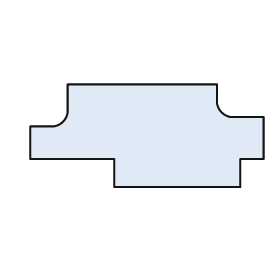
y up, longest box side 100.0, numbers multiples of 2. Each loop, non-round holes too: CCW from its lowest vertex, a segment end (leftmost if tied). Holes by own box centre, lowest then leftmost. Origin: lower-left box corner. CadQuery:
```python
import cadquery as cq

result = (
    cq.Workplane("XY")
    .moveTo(36.0, 0.0)
    .lineTo(90.0, 0.0)
    .lineTo(90.0, 12.0)
    .lineTo(100.0, 12.0)
    .lineTo(100.0, 30.0)
    .lineTo(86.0, 30.0)
    .threePointArc((82.0, 32.0), (80.0, 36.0))
    .lineTo(80.0, 44.0)
    .lineTo(16.0, 44.0)
    .lineTo(16.0, 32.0)
    .threePointArc((14.0, 28.0), (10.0, 26.0))
    .lineTo(0.0, 26.0)
    .lineTo(0.0, 12.0)
    .lineTo(36.0, 12.0)
    .close()
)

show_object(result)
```